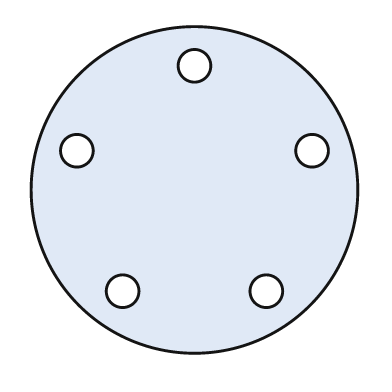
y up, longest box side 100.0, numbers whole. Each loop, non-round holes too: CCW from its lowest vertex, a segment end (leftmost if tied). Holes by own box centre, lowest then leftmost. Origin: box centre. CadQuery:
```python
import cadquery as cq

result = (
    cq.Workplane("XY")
    .moveTo(0.0, 0.0)
    .circle(50.0)
    .moveTo(-22.0, -31.0)
    .circle(5.0)
    .moveTo(22.0, -31.0)
    .circle(5.0)
    .moveTo(-36.0, 12.0)
    .circle(5.0)
    .moveTo(36.0, 12.0)
    .circle(5.0)
    .moveTo(0.0, 38.0)
    .circle(5.0)
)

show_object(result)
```